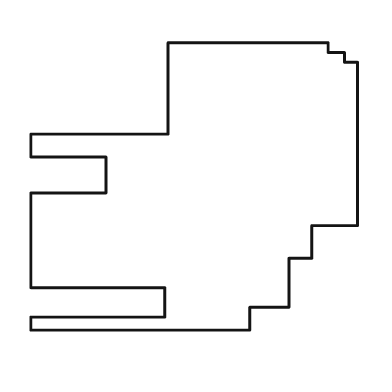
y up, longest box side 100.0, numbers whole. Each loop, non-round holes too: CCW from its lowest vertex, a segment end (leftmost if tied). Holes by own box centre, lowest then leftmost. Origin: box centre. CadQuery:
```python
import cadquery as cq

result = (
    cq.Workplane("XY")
    .moveTo(-50.0, -44.0)
    .lineTo(17.0, -44.0)
    .lineTo(17.0, -37.0)
    .lineTo(29.0, -37.0)
    .lineTo(29.0, -22.0)
    .lineTo(36.0, -22.0)
    .lineTo(36.0, -12.0)
    .lineTo(50.0, -12.0)
    .lineTo(50.0, 38.0)
    .lineTo(46.0, 38.0)
    .lineTo(46.0, 41.0)
    .lineTo(41.0, 41.0)
    .lineTo(41.0, 44.0)
    .lineTo(-8.0, 44.0)
    .lineTo(-8.0, 16.0)
    .lineTo(-50.0, 16.0)
    .lineTo(-50.0, 9.0)
    .lineTo(-27.0, 9.0)
    .lineTo(-27.0, -2.0)
    .lineTo(-50.0, -2.0)
    .lineTo(-50.0, -31.0)
    .lineTo(-9.0, -31.0)
    .lineTo(-9.0, -40.0)
    .lineTo(-50.0, -40.0)
    .close()
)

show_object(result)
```